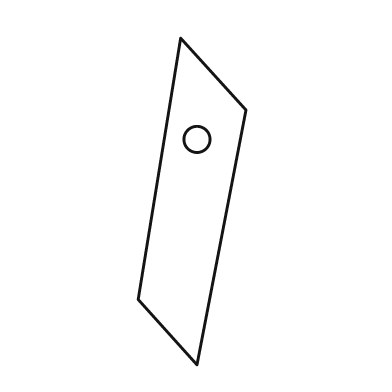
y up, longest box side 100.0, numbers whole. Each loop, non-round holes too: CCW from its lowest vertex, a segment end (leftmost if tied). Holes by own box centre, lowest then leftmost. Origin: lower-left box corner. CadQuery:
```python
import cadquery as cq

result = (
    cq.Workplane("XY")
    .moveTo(18.0, 0.0)
    .lineTo(33.0, 78.0)
    .lineTo(13.0, 100.0)
    .lineTo(0.0, 20.0)
    .close()
    .moveTo(18.0, 69.0)
    .circle(4.0)
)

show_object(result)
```